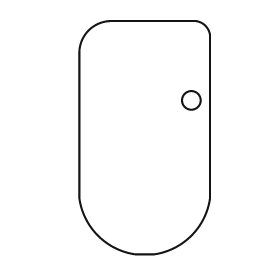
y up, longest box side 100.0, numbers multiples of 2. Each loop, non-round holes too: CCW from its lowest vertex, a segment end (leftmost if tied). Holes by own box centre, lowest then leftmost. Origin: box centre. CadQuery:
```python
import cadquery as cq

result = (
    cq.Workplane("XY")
    .moveTo(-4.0, -50.0)
    .lineTo(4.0, -50.0)
    .threePointArc((20.0, -42.0), (28.0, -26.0))
    .lineTo(28.0, 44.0)
    .threePointArc((26.0, 48.0), (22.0, 50.0))
    .lineTo(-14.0, 50.0)
    .threePointArc((-24.0, 46.0), (-28.0, 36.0))
    .lineTo(-28.0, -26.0)
    .threePointArc((-20.0, -42.0), (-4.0, -50.0))
    .close()
    .moveTo(20.0, 16.0)
    .circle(4.0)
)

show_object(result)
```